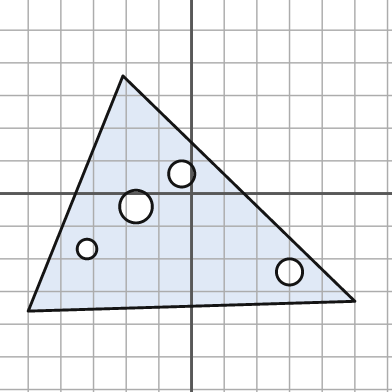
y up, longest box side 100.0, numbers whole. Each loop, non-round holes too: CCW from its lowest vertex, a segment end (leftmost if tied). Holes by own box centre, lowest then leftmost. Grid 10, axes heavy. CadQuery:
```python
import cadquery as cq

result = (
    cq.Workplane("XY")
    .moveTo(-50.0, -36.0)
    .lineTo(50.0, -33.0)
    .lineTo(-21.0, 36.0)
    .close()
    .moveTo(30.0, -24.0)
    .circle(4.0)
    .moveTo(-32.0, -17.0)
    .circle(3.0)
    .moveTo(-17.0, -4.0)
    .circle(5.0)
    .moveTo(-3.0, 6.0)
    .circle(4.0)
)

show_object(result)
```